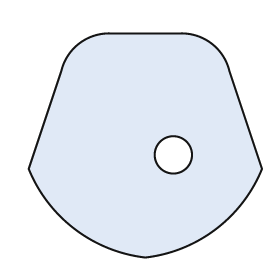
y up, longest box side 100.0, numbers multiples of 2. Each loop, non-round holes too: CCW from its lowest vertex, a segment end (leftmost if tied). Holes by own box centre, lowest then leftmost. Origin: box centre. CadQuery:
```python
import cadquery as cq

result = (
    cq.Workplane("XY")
    .moveTo(0.0, -48.0)
    .threePointArc((30.0, -36.0), (50.0, -10.0))
    .lineTo(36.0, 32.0)
    .threePointArc((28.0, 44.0), (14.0, 48.0))
    .lineTo(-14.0, 48.0)
    .threePointArc((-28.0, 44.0), (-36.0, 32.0))
    .lineTo(-50.0, -10.0)
    .threePointArc((-30.0, -36.0), (0.0, -48.0))
    .close()
    .moveTo(12.0, -4.0)
    .circle(8.0)
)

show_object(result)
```